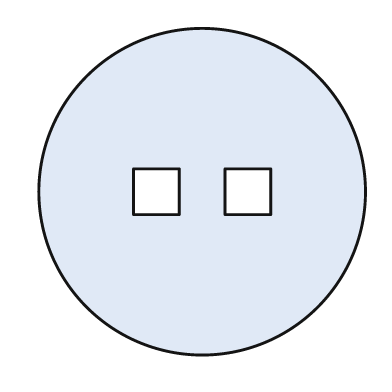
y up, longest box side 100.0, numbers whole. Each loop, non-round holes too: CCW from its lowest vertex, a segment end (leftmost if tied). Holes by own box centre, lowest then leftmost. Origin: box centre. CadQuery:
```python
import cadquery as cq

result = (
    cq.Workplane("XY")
    .moveTo(0.0, 0.0)
    .circle(50.0)
    .moveTo(-21.0, -7.0)
    .lineTo(-7.0, -7.0)
    .lineTo(-7.0, 7.0)
    .lineTo(-21.0, 7.0)
    .close()
    .moveTo(7.0, -7.0)
    .lineTo(21.0, -7.0)
    .lineTo(21.0, 7.0)
    .lineTo(7.0, 7.0)
    .close()
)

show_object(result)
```